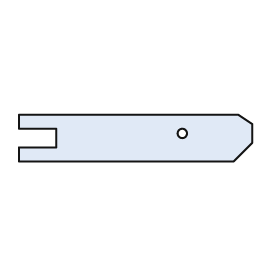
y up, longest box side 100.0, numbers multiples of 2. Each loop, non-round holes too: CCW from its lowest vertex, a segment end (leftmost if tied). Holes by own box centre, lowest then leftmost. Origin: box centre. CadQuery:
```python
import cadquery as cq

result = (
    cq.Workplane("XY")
    .moveTo(-50.0, -10.0)
    .lineTo(42.0, -10.0)
    .lineTo(50.0, -2.0)
    .lineTo(50.0, 6.0)
    .lineTo(44.0, 10.0)
    .lineTo(-50.0, 10.0)
    .lineTo(-50.0, 4.0)
    .lineTo(-34.0, 4.0)
    .lineTo(-34.0, -4.0)
    .lineTo(-50.0, -4.0)
    .close()
    .moveTo(20.0, 2.0)
    .circle(2.0)
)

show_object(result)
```